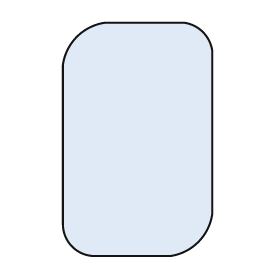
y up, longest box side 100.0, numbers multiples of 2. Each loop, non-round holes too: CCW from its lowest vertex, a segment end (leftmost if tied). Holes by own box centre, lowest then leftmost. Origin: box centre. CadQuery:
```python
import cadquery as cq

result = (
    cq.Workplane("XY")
    .moveTo(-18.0, -50.0)
    .lineTo(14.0, -50.0)
    .threePointArc((26.0, -44.0), (32.0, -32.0))
    .lineTo(32.0, 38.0)
    .threePointArc((28.0, 46.0), (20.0, 50.0))
    .lineTo(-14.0, 50.0)
    .threePointArc((-26.0, 44.0), (-32.0, 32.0))
    .lineTo(-32.0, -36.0)
    .threePointArc((-28.0, -46.0), (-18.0, -50.0))
    .close()
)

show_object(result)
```